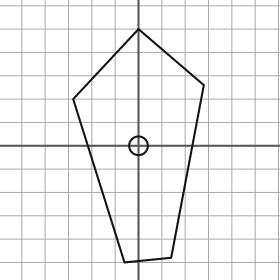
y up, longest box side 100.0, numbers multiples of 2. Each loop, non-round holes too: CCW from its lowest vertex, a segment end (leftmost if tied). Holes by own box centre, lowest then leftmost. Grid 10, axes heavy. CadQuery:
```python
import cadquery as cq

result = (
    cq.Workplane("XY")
    .moveTo(-6.0, -50.0)
    .lineTo(14.0, -48.0)
    .lineTo(28.0, 26.0)
    .lineTo(0.0, 50.0)
    .lineTo(-28.0, 20.0)
    .close()
    .moveTo(0.0, 0.0)
    .circle(4.0)
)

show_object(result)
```